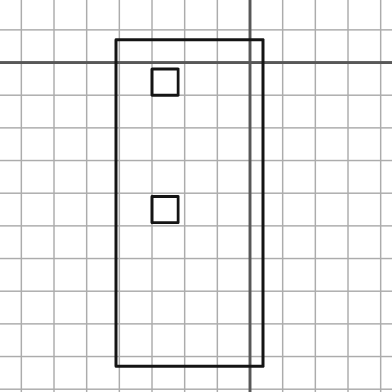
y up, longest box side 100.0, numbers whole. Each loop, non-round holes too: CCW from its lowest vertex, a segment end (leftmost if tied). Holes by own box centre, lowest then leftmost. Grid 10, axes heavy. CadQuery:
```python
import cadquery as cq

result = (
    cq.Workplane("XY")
    .moveTo(-41.0, -93.0)
    .lineTo(4.0, -93.0)
    .lineTo(4.0, 7.0)
    .lineTo(-41.0, 7.0)
    .close()
    .moveTo(-30.0, -49.0)
    .lineTo(-22.0, -49.0)
    .lineTo(-22.0, -41.0)
    .lineTo(-30.0, -41.0)
    .close()
    .moveTo(-30.0, -10.0)
    .lineTo(-22.0, -10.0)
    .lineTo(-22.0, -2.0)
    .lineTo(-30.0, -2.0)
    .close()
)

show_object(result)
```